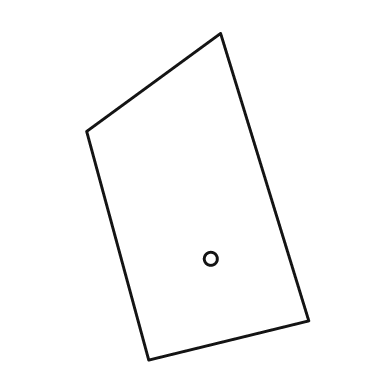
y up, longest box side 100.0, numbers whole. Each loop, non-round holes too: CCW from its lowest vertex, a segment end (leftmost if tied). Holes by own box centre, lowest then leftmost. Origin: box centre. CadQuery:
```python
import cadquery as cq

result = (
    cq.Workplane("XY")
    .moveTo(-15.0, -50.0)
    .lineTo(34.0, -38.0)
    .lineTo(7.0, 50.0)
    .lineTo(-34.0, 20.0)
    .close()
    .moveTo(4.0, -19.0)
    .circle(2.0)
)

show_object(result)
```